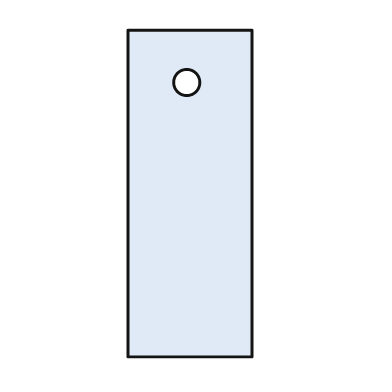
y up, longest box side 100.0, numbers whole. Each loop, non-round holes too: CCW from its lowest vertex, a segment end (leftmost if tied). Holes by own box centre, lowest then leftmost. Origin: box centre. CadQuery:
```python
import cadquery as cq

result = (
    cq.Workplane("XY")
    .moveTo(-19.0, -50.0)
    .lineTo(19.0, -50.0)
    .lineTo(19.0, 50.0)
    .lineTo(-19.0, 50.0)
    .close()
    .moveTo(-1.0, 34.0)
    .circle(4.0)
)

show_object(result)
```